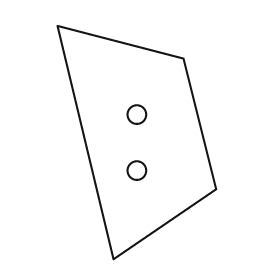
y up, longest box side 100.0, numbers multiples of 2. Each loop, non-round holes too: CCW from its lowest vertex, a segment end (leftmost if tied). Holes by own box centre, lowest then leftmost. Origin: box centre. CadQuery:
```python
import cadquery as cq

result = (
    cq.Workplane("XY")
    .moveTo(-10.0, -50.0)
    .lineTo(34.0, -20.0)
    .lineTo(20.0, 36.0)
    .lineTo(-34.0, 50.0)
    .close()
    .moveTo(0.0, -12.0)
    .circle(4.0)
    .moveTo(0.0, 12.0)
    .circle(4.0)
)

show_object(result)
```